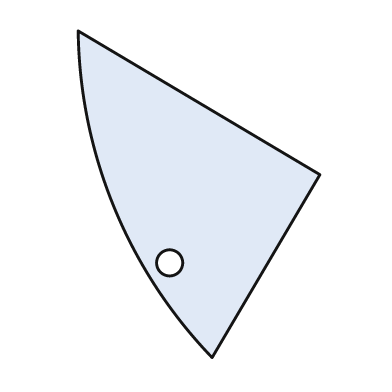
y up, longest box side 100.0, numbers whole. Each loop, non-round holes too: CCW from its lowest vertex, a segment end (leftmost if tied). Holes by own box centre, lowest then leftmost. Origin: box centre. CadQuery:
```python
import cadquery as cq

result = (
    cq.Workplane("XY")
    .moveTo(4.0, -50.0)
    .lineTo(37.0, 6.0)
    .lineTo(-37.0, 50.0)
    .threePointArc((-26.0, -4.0), (4.0, -50.0))
    .close()
    .moveTo(-9.0, -21.0)
    .circle(4.0)
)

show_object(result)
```